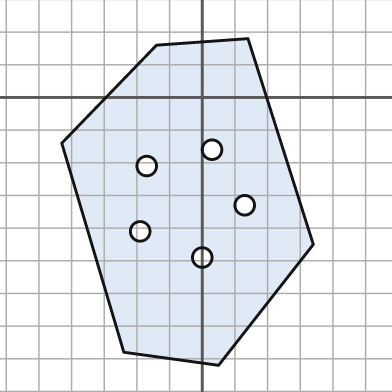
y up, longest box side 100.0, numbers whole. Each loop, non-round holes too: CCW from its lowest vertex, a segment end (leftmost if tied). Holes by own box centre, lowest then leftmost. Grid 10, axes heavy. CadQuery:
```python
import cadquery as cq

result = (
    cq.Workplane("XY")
    .moveTo(5.0, -82.0)
    .lineTo(34.0, -45.0)
    .lineTo(14.0, 18.0)
    .lineTo(-14.0, 16.0)
    .lineTo(-43.0, -14.0)
    .lineTo(-24.0, -78.0)
    .close()
    .moveTo(0.0, -49.0)
    .circle(3.0)
    .moveTo(-19.0, -41.0)
    .circle(3.0)
    .moveTo(13.0, -33.0)
    .circle(3.0)
    .moveTo(-17.0, -21.0)
    .circle(3.0)
    .moveTo(3.0, -16.0)
    .circle(3.0)
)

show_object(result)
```